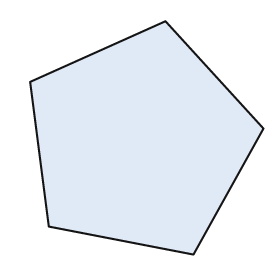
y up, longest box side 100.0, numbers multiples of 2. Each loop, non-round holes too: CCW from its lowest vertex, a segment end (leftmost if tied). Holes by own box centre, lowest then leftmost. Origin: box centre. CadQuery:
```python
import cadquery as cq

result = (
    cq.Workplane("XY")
    .moveTo(20.0, -50.0)
    .lineTo(50.0, 4.0)
    .lineTo(8.0, 50.0)
    .lineTo(-50.0, 24.0)
    .lineTo(-42.0, -38.0)
    .close()
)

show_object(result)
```